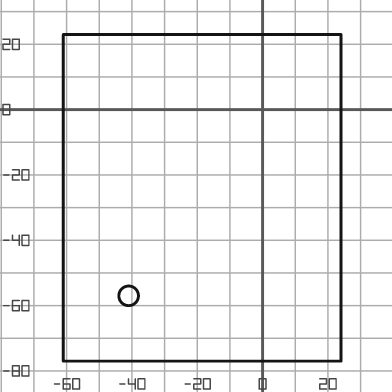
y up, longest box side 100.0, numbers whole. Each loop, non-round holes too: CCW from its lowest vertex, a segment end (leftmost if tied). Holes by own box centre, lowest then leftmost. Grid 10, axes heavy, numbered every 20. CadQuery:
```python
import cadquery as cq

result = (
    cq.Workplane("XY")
    .moveTo(-61.0, -77.0)
    .lineTo(24.0, -77.0)
    .lineTo(24.0, 23.0)
    .lineTo(-61.0, 23.0)
    .close()
    .moveTo(-41.0, -57.0)
    .circle(3.0)
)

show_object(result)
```